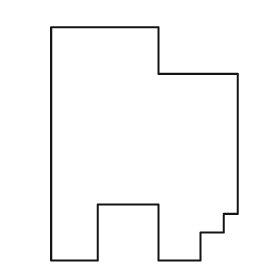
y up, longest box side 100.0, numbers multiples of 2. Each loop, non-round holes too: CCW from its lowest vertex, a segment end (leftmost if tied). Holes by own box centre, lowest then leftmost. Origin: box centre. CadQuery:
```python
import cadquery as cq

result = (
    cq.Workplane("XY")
    .moveTo(-40.0, -50.0)
    .lineTo(-20.0, -50.0)
    .lineTo(-20.0, -26.0)
    .lineTo(6.0, -26.0)
    .lineTo(6.0, -50.0)
    .lineTo(24.0, -50.0)
    .lineTo(24.0, -38.0)
    .lineTo(34.0, -38.0)
    .lineTo(34.0, -30.0)
    .lineTo(40.0, -30.0)
    .lineTo(40.0, 30.0)
    .lineTo(6.0, 30.0)
    .lineTo(6.0, 50.0)
    .lineTo(-40.0, 50.0)
    .close()
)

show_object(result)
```